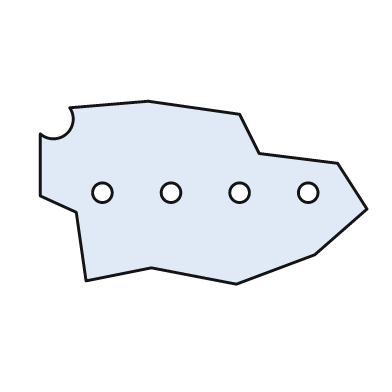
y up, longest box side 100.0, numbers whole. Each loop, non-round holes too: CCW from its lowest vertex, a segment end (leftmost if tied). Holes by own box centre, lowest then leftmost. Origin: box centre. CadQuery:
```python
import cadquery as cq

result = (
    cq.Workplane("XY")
    .moveTo(10.0, -28.0)
    .lineTo(34.0, -19.0)
    .lineTo(50.0, -5.0)
    .lineTo(41.0, 9.0)
    .lineTo(17.0, 12.0)
    .lineTo(11.0, 24.0)
    .lineTo(-17.0, 28.0)
    .lineTo(-41.0, 26.0)
    .threePointArc((-42.0, 18.0), (-50.0, 18.0))
    .lineTo(-50.0, -1.0)
    .lineTo(-39.0, -6.0)
    .lineTo(-36.0, -27.0)
    .lineTo(-16.0, -23.0)
    .close()
    .moveTo(-31.0, 0.0)
    .circle(3.0)
    .moveTo(-10.0, 0.0)
    .circle(3.0)
    .moveTo(11.0, 0.0)
    .circle(3.0)
    .moveTo(32.0, 0.0)
    .circle(3.0)
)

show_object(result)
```